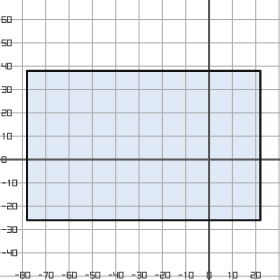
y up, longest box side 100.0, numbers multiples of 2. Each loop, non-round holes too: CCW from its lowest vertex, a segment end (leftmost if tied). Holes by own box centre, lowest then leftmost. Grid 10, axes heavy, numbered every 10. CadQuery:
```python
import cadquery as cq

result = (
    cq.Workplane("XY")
    .moveTo(-78.0, -26.0)
    .lineTo(22.0, -26.0)
    .lineTo(22.0, 38.0)
    .lineTo(-78.0, 38.0)
    .close()
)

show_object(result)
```